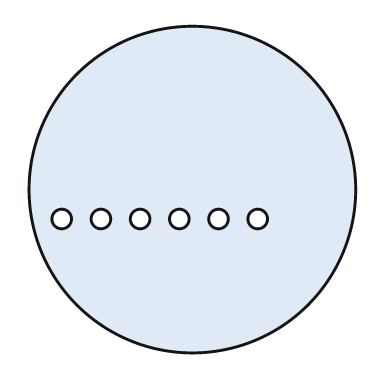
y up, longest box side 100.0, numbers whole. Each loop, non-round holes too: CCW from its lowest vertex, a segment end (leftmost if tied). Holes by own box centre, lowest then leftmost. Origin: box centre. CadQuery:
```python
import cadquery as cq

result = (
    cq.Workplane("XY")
    .moveTo(0.0, 0.0)
    .circle(50.0)
    .moveTo(-40.0, -9.0)
    .circle(3.0)
    .moveTo(-28.0, -9.0)
    .circle(3.0)
    .moveTo(-16.0, -9.0)
    .circle(3.0)
    .moveTo(-4.0, -9.0)
    .circle(3.0)
    .moveTo(8.0, -9.0)
    .circle(3.0)
    .moveTo(20.0, -9.0)
    .circle(3.0)
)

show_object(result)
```